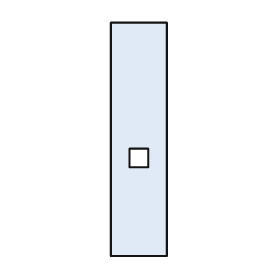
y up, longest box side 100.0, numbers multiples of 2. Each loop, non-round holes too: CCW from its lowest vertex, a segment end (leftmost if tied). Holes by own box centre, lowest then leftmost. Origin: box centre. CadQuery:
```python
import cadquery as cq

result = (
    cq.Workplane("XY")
    .moveTo(-12.0, -50.0)
    .lineTo(12.0, -50.0)
    .lineTo(12.0, 50.0)
    .lineTo(-12.0, 50.0)
    .close()
    .moveTo(-4.0, -12.0)
    .lineTo(4.0, -12.0)
    .lineTo(4.0, -4.0)
    .lineTo(-4.0, -4.0)
    .close()
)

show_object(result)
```